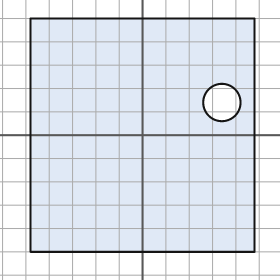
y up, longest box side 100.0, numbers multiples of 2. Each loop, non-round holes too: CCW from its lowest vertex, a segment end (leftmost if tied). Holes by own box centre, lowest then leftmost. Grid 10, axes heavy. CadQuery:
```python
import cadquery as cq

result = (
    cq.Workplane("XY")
    .moveTo(-48.0, -50.0)
    .lineTo(48.0, -50.0)
    .lineTo(48.0, 50.0)
    .lineTo(-48.0, 50.0)
    .close()
    .moveTo(34.0, 14.0)
    .circle(8.0)
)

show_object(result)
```